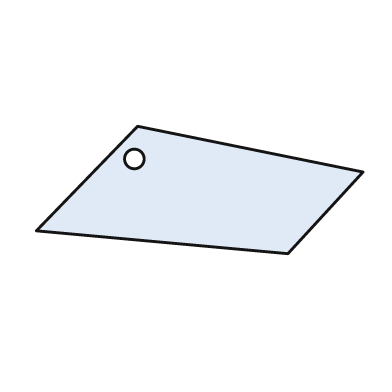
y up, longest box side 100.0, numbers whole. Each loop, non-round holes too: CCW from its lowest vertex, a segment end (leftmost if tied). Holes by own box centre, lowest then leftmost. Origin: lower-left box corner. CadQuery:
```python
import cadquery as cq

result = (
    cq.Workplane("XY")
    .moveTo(77.0, 0.0)
    .lineTo(100.0, 25.0)
    .lineTo(31.0, 39.0)
    .lineTo(0.0, 7.0)
    .close()
    .moveTo(30.0, 29.0)
    .circle(3.0)
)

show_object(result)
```